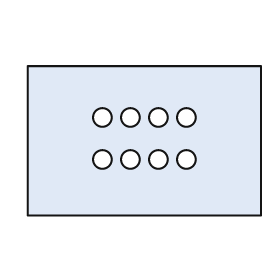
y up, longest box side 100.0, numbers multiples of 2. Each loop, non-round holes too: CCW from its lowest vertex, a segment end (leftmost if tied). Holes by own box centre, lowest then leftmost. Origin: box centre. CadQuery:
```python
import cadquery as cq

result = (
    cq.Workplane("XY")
    .moveTo(-50.0, -32.0)
    .lineTo(50.0, -32.0)
    .lineTo(50.0, 32.0)
    .lineTo(-50.0, 32.0)
    .close()
    .moveTo(-18.0, -8.0)
    .circle(4.0)
    .moveTo(-6.0, -8.0)
    .circle(4.0)
    .moveTo(6.0, -8.0)
    .circle(4.0)
    .moveTo(18.0, -8.0)
    .circle(4.0)
    .moveTo(-18.0, 10.0)
    .circle(4.0)
    .moveTo(-6.0, 10.0)
    .circle(4.0)
    .moveTo(6.0, 10.0)
    .circle(4.0)
    .moveTo(18.0, 10.0)
    .circle(4.0)
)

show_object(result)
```